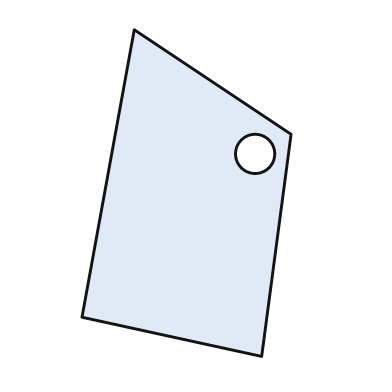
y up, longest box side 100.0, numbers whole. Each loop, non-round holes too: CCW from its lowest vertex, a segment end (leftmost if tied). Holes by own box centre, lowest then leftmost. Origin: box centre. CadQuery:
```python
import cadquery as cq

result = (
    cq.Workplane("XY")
    .moveTo(23.0, -50.0)
    .lineTo(32.0, 18.0)
    .lineTo(-16.0, 50.0)
    .lineTo(-32.0, -38.0)
    .close()
    .moveTo(21.0, 12.0)
    .circle(6.0)
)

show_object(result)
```